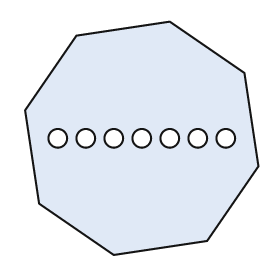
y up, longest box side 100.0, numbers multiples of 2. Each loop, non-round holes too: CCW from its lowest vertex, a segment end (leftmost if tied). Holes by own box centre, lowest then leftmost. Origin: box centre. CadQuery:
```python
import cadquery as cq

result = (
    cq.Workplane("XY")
    .moveTo(-12.0, -50.0)
    .lineTo(28.0, -44.0)
    .lineTo(50.0, -12.0)
    .lineTo(44.0, 28.0)
    .lineTo(12.0, 50.0)
    .lineTo(-28.0, 44.0)
    .lineTo(-50.0, 12.0)
    .lineTo(-44.0, -28.0)
    .close()
    .moveTo(-36.0, 0.0)
    .circle(4.0)
    .moveTo(-24.0, 0.0)
    .circle(4.0)
    .moveTo(-12.0, 0.0)
    .circle(4.0)
    .moveTo(0.0, 0.0)
    .circle(4.0)
    .moveTo(12.0, 0.0)
    .circle(4.0)
    .moveTo(24.0, 0.0)
    .circle(4.0)
    .moveTo(36.0, 0.0)
    .circle(4.0)
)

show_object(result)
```